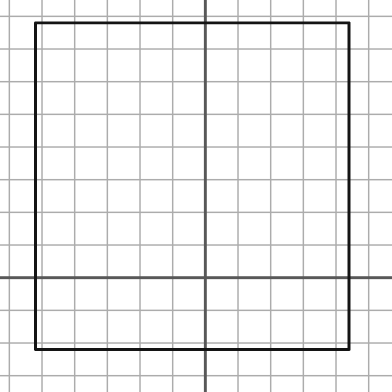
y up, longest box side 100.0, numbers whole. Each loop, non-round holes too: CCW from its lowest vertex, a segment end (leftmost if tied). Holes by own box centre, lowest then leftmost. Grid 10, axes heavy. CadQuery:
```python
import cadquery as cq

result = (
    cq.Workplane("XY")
    .moveTo(-52.0, -22.0)
    .lineTo(44.0, -22.0)
    .lineTo(44.0, 78.0)
    .lineTo(-52.0, 78.0)
    .close()
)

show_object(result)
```